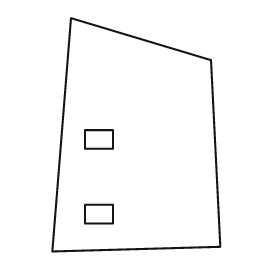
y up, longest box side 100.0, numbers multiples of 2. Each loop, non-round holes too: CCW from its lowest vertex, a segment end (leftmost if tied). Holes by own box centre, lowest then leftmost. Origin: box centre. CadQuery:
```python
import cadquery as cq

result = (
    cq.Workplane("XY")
    .moveTo(-36.0, -50.0)
    .lineTo(36.0, -48.0)
    .lineTo(32.0, 32.0)
    .lineTo(-28.0, 50.0)
    .close()
    .moveTo(-22.0, -38.0)
    .lineTo(-10.0, -38.0)
    .lineTo(-10.0, -30.0)
    .lineTo(-22.0, -30.0)
    .close()
    .moveTo(-22.0, -6.0)
    .lineTo(-10.0, -6.0)
    .lineTo(-10.0, 2.0)
    .lineTo(-22.0, 2.0)
    .close()
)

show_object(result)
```